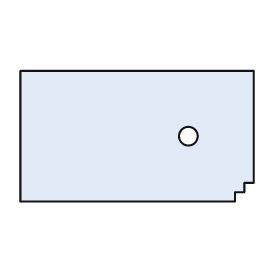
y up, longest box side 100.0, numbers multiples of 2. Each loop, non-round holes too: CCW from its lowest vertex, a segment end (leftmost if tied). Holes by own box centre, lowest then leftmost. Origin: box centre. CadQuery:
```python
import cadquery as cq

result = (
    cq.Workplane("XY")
    .moveTo(-50.0, -28.0)
    .lineTo(42.0, -28.0)
    .lineTo(42.0, -24.0)
    .lineTo(46.0, -24.0)
    .lineTo(46.0, -20.0)
    .lineTo(50.0, -20.0)
    .lineTo(50.0, 28.0)
    .lineTo(-50.0, 28.0)
    .close()
    .moveTo(22.0, 0.0)
    .circle(4.0)
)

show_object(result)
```